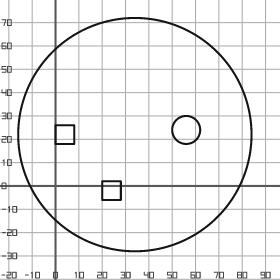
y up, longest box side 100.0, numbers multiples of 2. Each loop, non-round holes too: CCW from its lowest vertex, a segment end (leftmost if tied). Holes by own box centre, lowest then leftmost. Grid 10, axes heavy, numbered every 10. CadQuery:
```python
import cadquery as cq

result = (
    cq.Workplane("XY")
    .moveTo(34.0, 22.0)
    .circle(50.0)
    .moveTo(20.0, -6.0)
    .lineTo(28.0, -6.0)
    .lineTo(28.0, 2.0)
    .lineTo(20.0, 2.0)
    .close()
    .moveTo(0.0, 18.0)
    .lineTo(8.0, 18.0)
    .lineTo(8.0, 26.0)
    .lineTo(0.0, 26.0)
    .close()
    .moveTo(56.0, 24.0)
    .circle(6.0)
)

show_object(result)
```